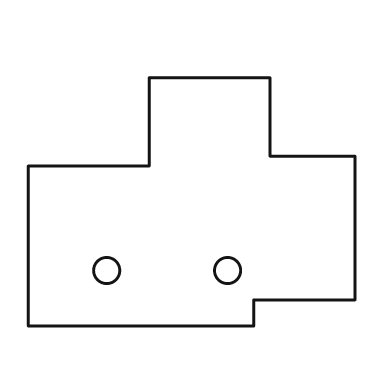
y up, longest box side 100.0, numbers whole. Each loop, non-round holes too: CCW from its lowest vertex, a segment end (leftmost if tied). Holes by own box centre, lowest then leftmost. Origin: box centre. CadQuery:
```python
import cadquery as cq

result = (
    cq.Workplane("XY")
    .moveTo(-50.0, -38.0)
    .lineTo(19.0, -38.0)
    .lineTo(19.0, -30.0)
    .lineTo(50.0, -30.0)
    .lineTo(50.0, 14.0)
    .lineTo(24.0, 14.0)
    .lineTo(24.0, 38.0)
    .lineTo(-13.0, 38.0)
    .lineTo(-13.0, 11.0)
    .lineTo(-50.0, 11.0)
    .close()
    .moveTo(-26.0, -21.0)
    .circle(4.0)
    .moveTo(11.0, -21.0)
    .circle(4.0)
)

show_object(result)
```